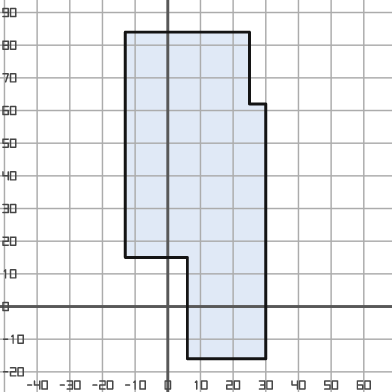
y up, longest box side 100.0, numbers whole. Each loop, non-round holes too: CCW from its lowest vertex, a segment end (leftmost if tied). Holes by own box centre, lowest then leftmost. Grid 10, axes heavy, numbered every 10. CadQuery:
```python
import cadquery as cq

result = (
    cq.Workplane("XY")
    .moveTo(6.0, -16.0)
    .lineTo(30.0, -16.0)
    .lineTo(30.0, 62.0)
    .lineTo(25.0, 62.0)
    .lineTo(25.0, 84.0)
    .lineTo(-13.0, 84.0)
    .lineTo(-13.0, 15.0)
    .lineTo(6.0, 15.0)
    .close()
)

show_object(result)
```